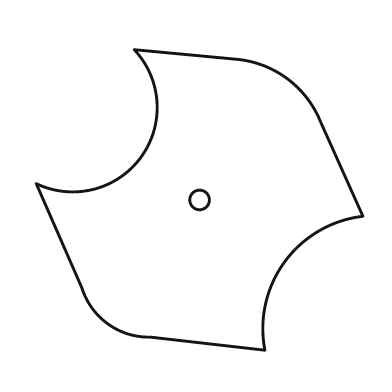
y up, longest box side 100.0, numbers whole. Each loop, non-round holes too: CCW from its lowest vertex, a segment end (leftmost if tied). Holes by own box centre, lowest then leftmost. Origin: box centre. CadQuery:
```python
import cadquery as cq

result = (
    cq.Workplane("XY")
    .moveTo(20.0, -46.0)
    .threePointArc((26.0, -19.0), (50.0, -5.0))
    .lineTo(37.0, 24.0)
    .threePointArc((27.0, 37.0), (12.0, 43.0))
    .lineTo(-20.0, 46.0)
    .threePointArc((-18.0, 13.0), (-50.0, 5.0))
    .lineTo(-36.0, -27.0)
    .threePointArc((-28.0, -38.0), (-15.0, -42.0))
    .close()
    .moveTo(0.0, 0.0)
    .circle(3.0)
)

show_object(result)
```